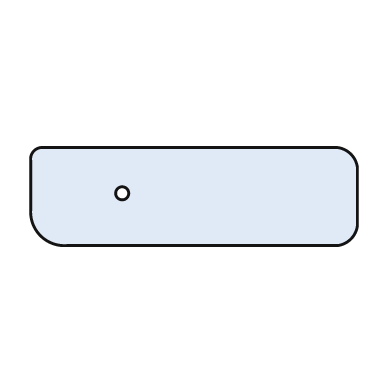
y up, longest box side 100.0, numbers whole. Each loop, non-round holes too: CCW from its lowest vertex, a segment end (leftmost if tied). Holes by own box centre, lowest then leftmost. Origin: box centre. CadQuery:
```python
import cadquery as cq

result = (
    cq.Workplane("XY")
    .moveTo(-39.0, -15.0)
    .lineTo(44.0, -15.0)
    .threePointArc((48.0, -13.0), (50.0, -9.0))
    .lineTo(50.0, 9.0)
    .threePointArc((48.0, 13.0), (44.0, 15.0))
    .lineTo(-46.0, 15.0)
    .threePointArc((-49.0, 14.0), (-50.0, 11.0))
    .lineTo(-50.0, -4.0)
    .threePointArc((-47.0, -12.0), (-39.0, -15.0))
    .close()
    .moveTo(-22.0, 1.0)
    .circle(2.0)
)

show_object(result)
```